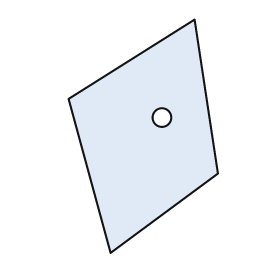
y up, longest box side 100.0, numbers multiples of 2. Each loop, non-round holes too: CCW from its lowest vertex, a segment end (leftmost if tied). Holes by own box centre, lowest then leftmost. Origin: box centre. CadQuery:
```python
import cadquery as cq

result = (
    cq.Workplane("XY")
    .moveTo(-14.0, -50.0)
    .lineTo(32.0, -16.0)
    .lineTo(22.0, 50.0)
    .lineTo(-32.0, 16.0)
    .close()
    .moveTo(8.0, 8.0)
    .circle(4.0)
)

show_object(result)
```